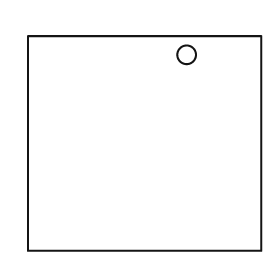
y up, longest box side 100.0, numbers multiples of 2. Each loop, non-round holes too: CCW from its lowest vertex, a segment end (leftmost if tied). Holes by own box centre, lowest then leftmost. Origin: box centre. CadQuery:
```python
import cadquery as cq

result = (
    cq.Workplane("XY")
    .moveTo(-50.0, -46.0)
    .lineTo(50.0, -46.0)
    .lineTo(50.0, 46.0)
    .lineTo(-50.0, 46.0)
    .close()
    .moveTo(18.0, 38.0)
    .circle(4.0)
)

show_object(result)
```